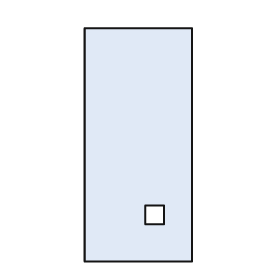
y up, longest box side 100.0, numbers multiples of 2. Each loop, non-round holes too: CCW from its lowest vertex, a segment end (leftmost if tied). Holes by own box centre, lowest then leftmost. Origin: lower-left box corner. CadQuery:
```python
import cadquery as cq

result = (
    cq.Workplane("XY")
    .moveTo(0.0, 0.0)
    .lineTo(46.0, 0.0)
    .lineTo(46.0, 100.0)
    .lineTo(0.0, 100.0)
    .close()
    .moveTo(26.0, 16.0)
    .lineTo(34.0, 16.0)
    .lineTo(34.0, 24.0)
    .lineTo(26.0, 24.0)
    .close()
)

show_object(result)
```